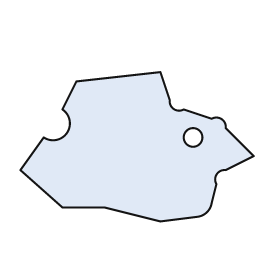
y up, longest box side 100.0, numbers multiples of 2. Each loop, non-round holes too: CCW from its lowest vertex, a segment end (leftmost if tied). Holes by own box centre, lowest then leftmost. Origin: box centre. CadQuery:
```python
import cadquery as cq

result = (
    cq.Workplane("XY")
    .moveTo(10.0, -32.0)
    .lineTo(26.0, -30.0)
    .threePointArc((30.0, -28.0), (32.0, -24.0))
    .lineTo(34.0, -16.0)
    .threePointArc((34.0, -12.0), (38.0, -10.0))
    .lineTo(50.0, -4.0)
    .lineTo(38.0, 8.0)
    .threePointArc((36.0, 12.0), (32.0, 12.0))
    .lineTo(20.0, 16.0)
    .threePointArc((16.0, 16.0), (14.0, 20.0))
    .lineTo(10.0, 32.0)
    .lineTo(-26.0, 28.0)
    .lineTo(-32.0, 16.0)
    .threePointArc((-30.0, 6.0), (-40.0, 4.0))
    .lineTo(-50.0, -10.0)
    .lineTo(-32.0, -26.0)
    .lineTo(-14.0, -26.0)
    .close()
    .moveTo(24.0, 4.0)
    .circle(4.0)
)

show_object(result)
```